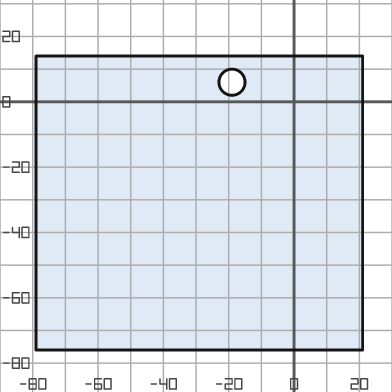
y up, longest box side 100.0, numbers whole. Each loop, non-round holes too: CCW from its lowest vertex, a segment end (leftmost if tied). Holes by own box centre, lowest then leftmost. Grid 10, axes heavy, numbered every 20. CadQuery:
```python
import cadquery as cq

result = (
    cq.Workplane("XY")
    .moveTo(-79.0, -76.0)
    .lineTo(21.0, -76.0)
    .lineTo(21.0, 14.0)
    .lineTo(-79.0, 14.0)
    .close()
    .moveTo(-19.0, 6.0)
    .circle(4.0)
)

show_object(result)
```